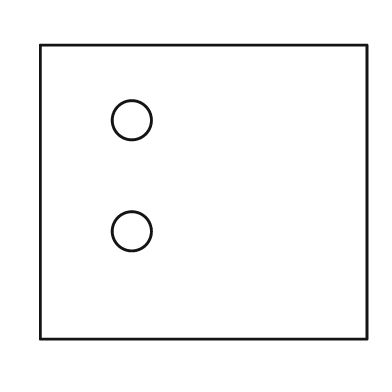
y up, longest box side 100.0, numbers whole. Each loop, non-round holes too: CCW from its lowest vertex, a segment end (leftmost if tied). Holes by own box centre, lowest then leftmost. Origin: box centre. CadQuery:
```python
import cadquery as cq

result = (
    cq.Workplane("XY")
    .moveTo(-50.0, -45.0)
    .lineTo(50.0, -45.0)
    .lineTo(50.0, 45.0)
    .lineTo(-50.0, 45.0)
    .close()
    .moveTo(-22.0, -12.0)
    .circle(6.0)
    .moveTo(-22.0, 22.0)
    .circle(6.0)
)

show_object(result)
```